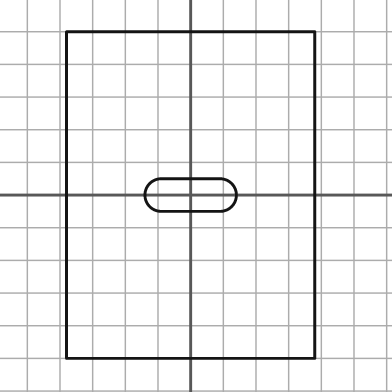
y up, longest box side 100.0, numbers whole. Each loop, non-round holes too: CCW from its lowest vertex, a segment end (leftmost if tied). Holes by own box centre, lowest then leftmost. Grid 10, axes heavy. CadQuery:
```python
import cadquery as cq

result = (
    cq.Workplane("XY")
    .moveTo(-38.0, -50.0)
    .lineTo(38.0, -50.0)
    .lineTo(38.0, 50.0)
    .lineTo(-38.0, 50.0)
    .close()
    .moveTo(-9.0, -5.0)
    .lineTo(9.0, -5.0)
    .threePointArc((14.0, 0.0), (9.0, 5.0))
    .lineTo(-9.0, 5.0)
    .threePointArc((-14.0, 0.0), (-9.0, -5.0))
    .close()
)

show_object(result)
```